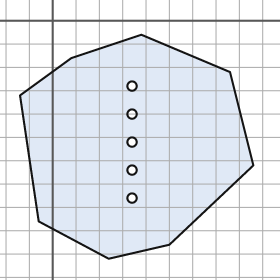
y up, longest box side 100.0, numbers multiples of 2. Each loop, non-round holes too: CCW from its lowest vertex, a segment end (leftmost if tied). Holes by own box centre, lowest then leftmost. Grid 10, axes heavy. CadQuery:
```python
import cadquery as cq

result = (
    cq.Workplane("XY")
    .moveTo(24.0, -102.0)
    .lineTo(50.0, -96.0)
    .lineTo(86.0, -62.0)
    .lineTo(76.0, -22.0)
    .lineTo(38.0, -6.0)
    .lineTo(8.0, -16.0)
    .lineTo(-14.0, -32.0)
    .lineTo(-6.0, -86.0)
    .close()
    .moveTo(34.0, -76.0)
    .circle(2.0)
    .moveTo(34.0, -64.0)
    .circle(2.0)
    .moveTo(34.0, -52.0)
    .circle(2.0)
    .moveTo(34.0, -40.0)
    .circle(2.0)
    .moveTo(34.0, -28.0)
    .circle(2.0)
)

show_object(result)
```